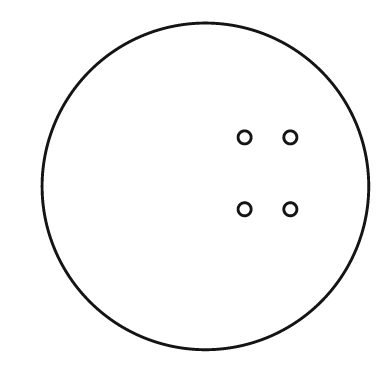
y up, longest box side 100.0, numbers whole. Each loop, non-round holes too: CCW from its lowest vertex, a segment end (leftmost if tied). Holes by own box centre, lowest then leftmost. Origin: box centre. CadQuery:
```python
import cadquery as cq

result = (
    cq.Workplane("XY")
    .moveTo(0.0, 0.0)
    .circle(50.0)
    .moveTo(12.0, -7.0)
    .circle(2.0)
    .moveTo(26.0, -7.0)
    .circle(2.0)
    .moveTo(12.0, 15.0)
    .circle(2.0)
    .moveTo(26.0, 15.0)
    .circle(2.0)
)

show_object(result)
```